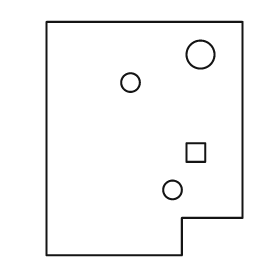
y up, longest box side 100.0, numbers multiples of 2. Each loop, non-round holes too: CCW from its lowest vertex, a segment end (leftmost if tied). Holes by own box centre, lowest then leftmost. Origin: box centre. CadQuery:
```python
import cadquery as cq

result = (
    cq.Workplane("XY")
    .moveTo(-42.0, -50.0)
    .lineTo(16.0, -50.0)
    .lineTo(16.0, -34.0)
    .lineTo(42.0, -34.0)
    .lineTo(42.0, 50.0)
    .lineTo(-42.0, 50.0)
    .close()
    .moveTo(12.0, -22.0)
    .circle(4.0)
    .moveTo(18.0, -10.0)
    .lineTo(26.0, -10.0)
    .lineTo(26.0, -2.0)
    .lineTo(18.0, -2.0)
    .close()
    .moveTo(-6.0, 24.0)
    .circle(4.0)
    .moveTo(24.0, 36.0)
    .circle(6.0)
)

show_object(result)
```